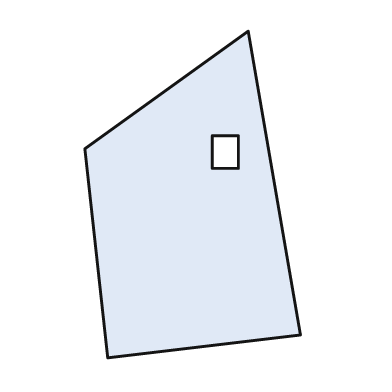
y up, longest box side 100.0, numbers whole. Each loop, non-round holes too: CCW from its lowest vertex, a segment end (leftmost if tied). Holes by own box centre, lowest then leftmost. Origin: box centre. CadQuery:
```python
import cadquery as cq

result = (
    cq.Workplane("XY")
    .moveTo(-26.0, -50.0)
    .lineTo(33.0, -43.0)
    .lineTo(17.0, 50.0)
    .lineTo(-33.0, 14.0)
    .close()
    .moveTo(6.0, 8.0)
    .lineTo(14.0, 8.0)
    .lineTo(14.0, 18.0)
    .lineTo(6.0, 18.0)
    .close()
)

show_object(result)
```